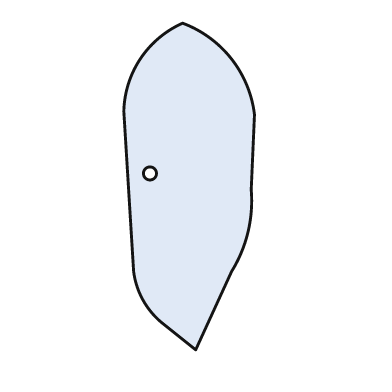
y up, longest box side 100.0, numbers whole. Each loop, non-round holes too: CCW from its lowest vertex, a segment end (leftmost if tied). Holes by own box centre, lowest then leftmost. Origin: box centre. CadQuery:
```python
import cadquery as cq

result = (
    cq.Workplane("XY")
    .moveTo(2.0, -50.0)
    .lineTo(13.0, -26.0)
    .threePointArc((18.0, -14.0), (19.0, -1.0))
    .lineTo(20.0, 22.0)
    .threePointArc((13.0, 39.0), (-2.0, 50.0))
    .threePointArc((-15.0, 39.0), (-20.0, 23.0))
    .lineTo(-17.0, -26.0)
    .threePointArc((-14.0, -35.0), (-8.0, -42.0))
    .close()
    .moveTo(-12.0, 4.0)
    .circle(2.0)
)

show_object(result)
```